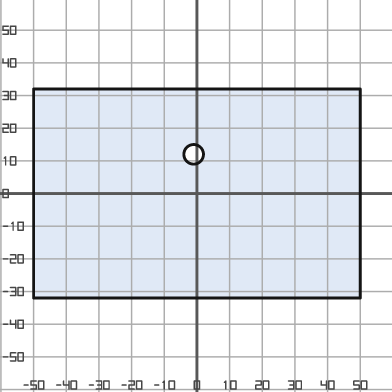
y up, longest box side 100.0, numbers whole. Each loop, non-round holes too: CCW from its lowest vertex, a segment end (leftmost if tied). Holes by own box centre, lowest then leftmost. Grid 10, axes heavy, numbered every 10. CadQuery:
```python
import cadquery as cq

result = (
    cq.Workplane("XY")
    .moveTo(-50.0, -32.0)
    .lineTo(50.0, -32.0)
    .lineTo(50.0, 32.0)
    .lineTo(-50.0, 32.0)
    .close()
    .moveTo(-1.0, 12.0)
    .circle(3.0)
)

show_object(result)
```